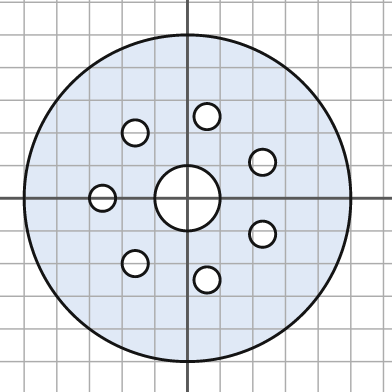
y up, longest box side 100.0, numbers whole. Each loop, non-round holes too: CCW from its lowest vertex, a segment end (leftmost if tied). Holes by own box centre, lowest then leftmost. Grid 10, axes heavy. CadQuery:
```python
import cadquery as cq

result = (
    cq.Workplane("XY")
    .moveTo(0.0, 0.0)
    .circle(50.0)
    .moveTo(6.0, -25.0)
    .circle(4.0)
    .moveTo(-16.0, -20.0)
    .circle(4.0)
    .moveTo(23.0, -11.0)
    .circle(4.0)
    .moveTo(-26.0, 0.0)
    .circle(4.0)
    .moveTo(0.0, 0.0)
    .circle(10.0)
    .moveTo(23.0, 11.0)
    .circle(4.0)
    .moveTo(-16.0, 20.0)
    .circle(4.0)
    .moveTo(6.0, 25.0)
    .circle(4.0)
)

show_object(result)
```